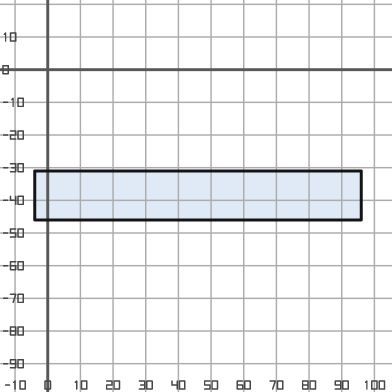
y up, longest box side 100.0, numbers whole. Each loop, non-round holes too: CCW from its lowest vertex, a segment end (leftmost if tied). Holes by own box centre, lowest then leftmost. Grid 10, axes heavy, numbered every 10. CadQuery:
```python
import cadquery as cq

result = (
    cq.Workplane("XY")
    .moveTo(-4.0, -46.0)
    .lineTo(96.0, -46.0)
    .lineTo(96.0, -31.0)
    .lineTo(-4.0, -31.0)
    .close()
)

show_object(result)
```